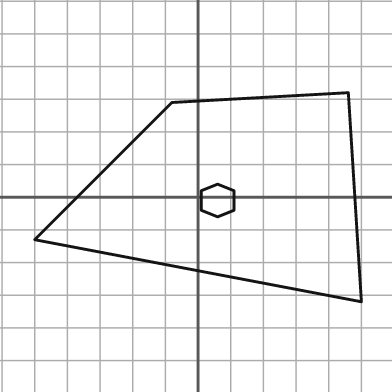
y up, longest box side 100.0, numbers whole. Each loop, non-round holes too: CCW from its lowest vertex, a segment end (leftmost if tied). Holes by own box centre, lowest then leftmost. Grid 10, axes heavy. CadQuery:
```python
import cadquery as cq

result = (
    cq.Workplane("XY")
    .moveTo(50.0, -32.0)
    .lineTo(46.0, 32.0)
    .lineTo(-8.0, 29.0)
    .lineTo(-50.0, -13.0)
    .close()
    .moveTo(6.0, -6.0)
    .lineTo(11.0, -4.0)
    .lineTo(11.0, 2.0)
    .lineTo(6.0, 4.0)
    .lineTo(1.0, 2.0)
    .lineTo(1.0, -4.0)
    .close()
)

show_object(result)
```